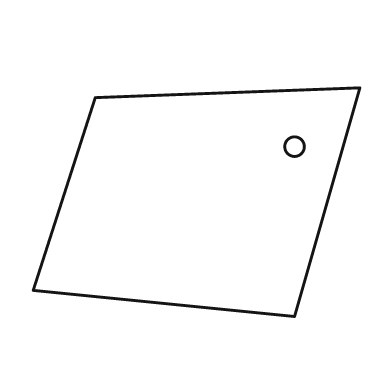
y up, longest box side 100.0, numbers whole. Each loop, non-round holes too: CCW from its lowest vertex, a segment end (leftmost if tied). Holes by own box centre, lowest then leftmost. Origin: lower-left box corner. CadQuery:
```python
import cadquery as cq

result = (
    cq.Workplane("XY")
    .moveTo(80.0, 0.0)
    .lineTo(100.0, 70.0)
    .lineTo(19.0, 67.0)
    .lineTo(0.0, 8.0)
    .close()
    .moveTo(80.0, 52.0)
    .circle(3.0)
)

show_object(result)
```